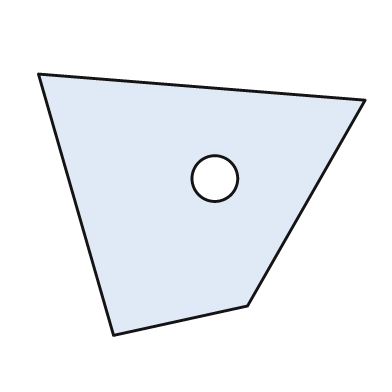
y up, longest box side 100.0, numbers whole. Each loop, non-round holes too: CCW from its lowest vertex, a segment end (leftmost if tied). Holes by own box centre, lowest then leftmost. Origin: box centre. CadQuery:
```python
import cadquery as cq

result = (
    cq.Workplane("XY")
    .moveTo(-27.0, -40.0)
    .lineTo(14.0, -31.0)
    .lineTo(50.0, 32.0)
    .lineTo(-50.0, 40.0)
    .close()
    .moveTo(4.0, 8.0)
    .circle(7.0)
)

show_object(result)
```